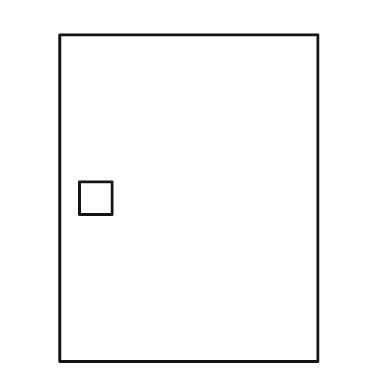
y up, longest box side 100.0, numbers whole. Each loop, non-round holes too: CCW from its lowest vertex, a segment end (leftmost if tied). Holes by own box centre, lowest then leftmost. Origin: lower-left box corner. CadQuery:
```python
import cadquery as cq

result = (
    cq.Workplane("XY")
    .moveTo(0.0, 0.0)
    .lineTo(79.0, 0.0)
    .lineTo(79.0, 100.0)
    .lineTo(0.0, 100.0)
    .close()
    .moveTo(6.0, 45.0)
    .lineTo(16.0, 45.0)
    .lineTo(16.0, 55.0)
    .lineTo(6.0, 55.0)
    .close()
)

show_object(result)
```